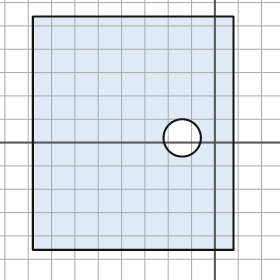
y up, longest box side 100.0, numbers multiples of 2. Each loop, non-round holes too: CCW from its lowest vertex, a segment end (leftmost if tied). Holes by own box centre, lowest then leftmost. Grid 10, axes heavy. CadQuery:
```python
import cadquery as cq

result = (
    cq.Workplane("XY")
    .moveTo(-78.0, -46.0)
    .lineTo(8.0, -46.0)
    .lineTo(8.0, 54.0)
    .lineTo(-78.0, 54.0)
    .close()
    .moveTo(-14.0, 2.0)
    .circle(8.0)
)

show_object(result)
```